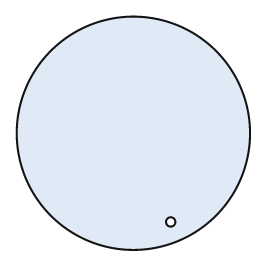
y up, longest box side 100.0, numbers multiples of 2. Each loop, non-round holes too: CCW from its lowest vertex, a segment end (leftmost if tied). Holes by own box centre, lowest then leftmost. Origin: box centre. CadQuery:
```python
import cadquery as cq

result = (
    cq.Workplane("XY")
    .moveTo(0.0, 0.0)
    .circle(50.0)
    .moveTo(16.0, -38.0)
    .circle(2.0)
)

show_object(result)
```